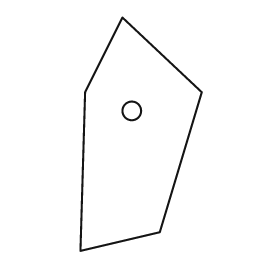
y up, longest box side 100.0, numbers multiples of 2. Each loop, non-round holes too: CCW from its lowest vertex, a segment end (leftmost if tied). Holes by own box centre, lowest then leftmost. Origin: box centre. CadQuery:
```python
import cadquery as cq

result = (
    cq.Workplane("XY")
    .moveTo(-26.0, -50.0)
    .lineTo(8.0, -42.0)
    .lineTo(26.0, 18.0)
    .lineTo(-8.0, 50.0)
    .lineTo(-24.0, 18.0)
    .close()
    .moveTo(-4.0, 10.0)
    .circle(4.0)
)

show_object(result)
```